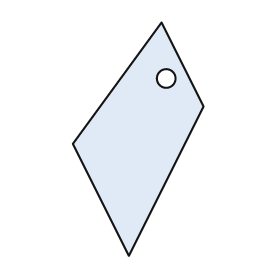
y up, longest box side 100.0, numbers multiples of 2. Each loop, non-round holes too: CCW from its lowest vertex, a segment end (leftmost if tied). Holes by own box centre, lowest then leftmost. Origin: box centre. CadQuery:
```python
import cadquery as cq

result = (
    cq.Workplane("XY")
    .moveTo(-4.0, -50.0)
    .lineTo(28.0, 14.0)
    .lineTo(10.0, 50.0)
    .lineTo(-28.0, -2.0)
    .close()
    .moveTo(12.0, 26.0)
    .circle(4.0)
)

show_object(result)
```